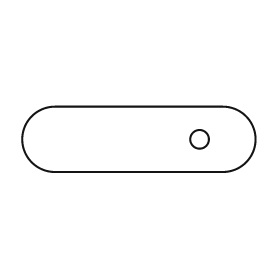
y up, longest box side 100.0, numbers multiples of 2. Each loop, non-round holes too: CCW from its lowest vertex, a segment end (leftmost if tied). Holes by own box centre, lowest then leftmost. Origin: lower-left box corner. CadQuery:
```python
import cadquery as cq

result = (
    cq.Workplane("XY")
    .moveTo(14.0, 0.0)
    .lineTo(86.0, 0.0)
    .threePointArc((100.0, 14.0), (86.0, 28.0))
    .lineTo(14.0, 28.0)
    .threePointArc((0.0, 14.0), (14.0, 0.0))
    .close()
    .moveTo(76.0, 14.0)
    .circle(4.0)
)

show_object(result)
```